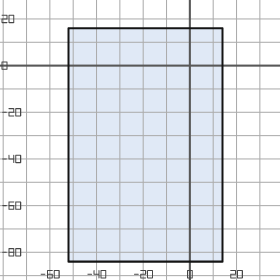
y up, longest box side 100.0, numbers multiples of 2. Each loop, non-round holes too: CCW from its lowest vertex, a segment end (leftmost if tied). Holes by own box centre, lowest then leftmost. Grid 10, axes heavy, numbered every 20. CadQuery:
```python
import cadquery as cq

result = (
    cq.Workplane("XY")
    .moveTo(-52.0, -84.0)
    .lineTo(14.0, -84.0)
    .lineTo(14.0, 16.0)
    .lineTo(-52.0, 16.0)
    .close()
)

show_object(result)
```